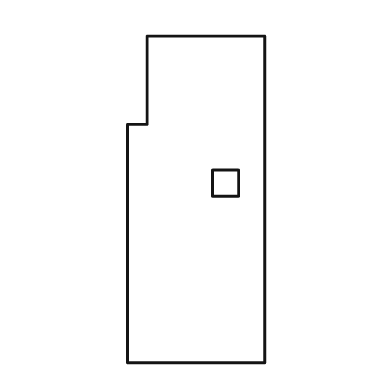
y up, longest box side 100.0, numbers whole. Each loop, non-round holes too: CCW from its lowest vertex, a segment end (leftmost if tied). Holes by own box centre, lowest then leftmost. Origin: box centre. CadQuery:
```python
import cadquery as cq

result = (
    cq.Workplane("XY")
    .moveTo(-21.0, -50.0)
    .lineTo(21.0, -50.0)
    .lineTo(21.0, 50.0)
    .lineTo(-15.0, 50.0)
    .lineTo(-15.0, 23.0)
    .lineTo(-21.0, 23.0)
    .close()
    .moveTo(5.0, 1.0)
    .lineTo(13.0, 1.0)
    .lineTo(13.0, 9.0)
    .lineTo(5.0, 9.0)
    .close()
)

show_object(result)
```